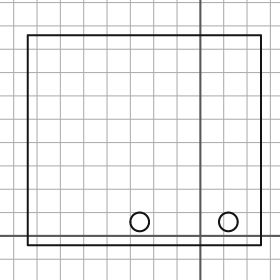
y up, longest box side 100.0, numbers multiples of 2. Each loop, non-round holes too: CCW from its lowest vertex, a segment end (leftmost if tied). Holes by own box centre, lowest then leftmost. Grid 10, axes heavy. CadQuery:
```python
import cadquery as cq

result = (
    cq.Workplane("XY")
    .moveTo(-74.0, -4.0)
    .lineTo(26.0, -4.0)
    .lineTo(26.0, 86.0)
    .lineTo(-74.0, 86.0)
    .close()
    .moveTo(-26.0, 6.0)
    .circle(4.0)
    .moveTo(12.0, 6.0)
    .circle(4.0)
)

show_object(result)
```